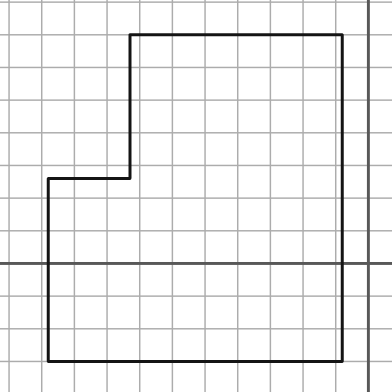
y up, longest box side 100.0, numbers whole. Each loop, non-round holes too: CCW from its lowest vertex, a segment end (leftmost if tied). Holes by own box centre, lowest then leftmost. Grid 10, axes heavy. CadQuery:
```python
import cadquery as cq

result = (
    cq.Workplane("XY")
    .moveTo(-98.0, -30.0)
    .lineTo(-8.0, -30.0)
    .lineTo(-8.0, 70.0)
    .lineTo(-73.0, 70.0)
    .lineTo(-73.0, 26.0)
    .lineTo(-98.0, 26.0)
    .close()
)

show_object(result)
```